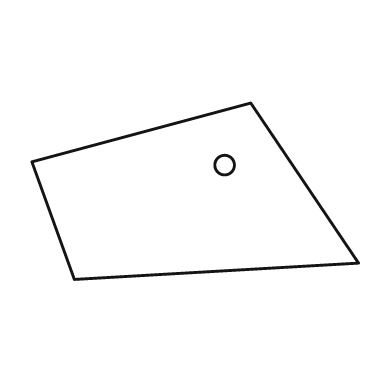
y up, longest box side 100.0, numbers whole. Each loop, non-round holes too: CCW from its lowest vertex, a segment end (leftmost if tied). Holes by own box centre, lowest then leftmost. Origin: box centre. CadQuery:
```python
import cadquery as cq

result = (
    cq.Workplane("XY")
    .moveTo(-37.0, -27.0)
    .lineTo(50.0, -22.0)
    .lineTo(17.0, 27.0)
    .lineTo(-50.0, 9.0)
    .close()
    .moveTo(9.0, 8.0)
    .circle(3.0)
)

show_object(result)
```